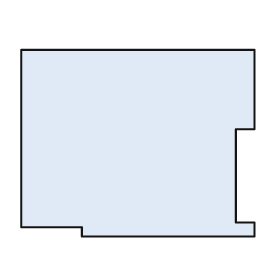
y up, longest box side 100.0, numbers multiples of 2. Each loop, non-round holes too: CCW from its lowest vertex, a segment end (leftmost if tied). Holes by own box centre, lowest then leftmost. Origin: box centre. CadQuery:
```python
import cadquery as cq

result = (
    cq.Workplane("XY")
    .moveTo(-24.0, -40.0)
    .lineTo(50.0, -40.0)
    .lineTo(50.0, -34.0)
    .lineTo(42.0, -34.0)
    .lineTo(42.0, 6.0)
    .lineTo(50.0, 6.0)
    .lineTo(50.0, 40.0)
    .lineTo(-50.0, 40.0)
    .lineTo(-50.0, -36.0)
    .lineTo(-24.0, -36.0)
    .close()
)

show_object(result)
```